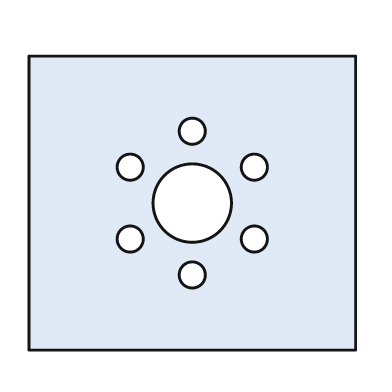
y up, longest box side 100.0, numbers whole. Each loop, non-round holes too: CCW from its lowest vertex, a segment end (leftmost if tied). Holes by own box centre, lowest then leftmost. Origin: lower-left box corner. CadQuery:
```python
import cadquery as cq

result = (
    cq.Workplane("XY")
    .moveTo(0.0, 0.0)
    .lineTo(100.0, 0.0)
    .lineTo(100.0, 90.0)
    .lineTo(0.0, 90.0)
    .close()
    .moveTo(50.0, 23.0)
    .circle(4.0)
    .moveTo(31.0, 34.0)
    .circle(4.0)
    .moveTo(69.0, 34.0)
    .circle(4.0)
    .moveTo(50.0, 45.0)
    .circle(12.0)
    .moveTo(31.0, 56.0)
    .circle(4.0)
    .moveTo(69.0, 56.0)
    .circle(4.0)
    .moveTo(50.0, 67.0)
    .circle(4.0)
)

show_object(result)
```